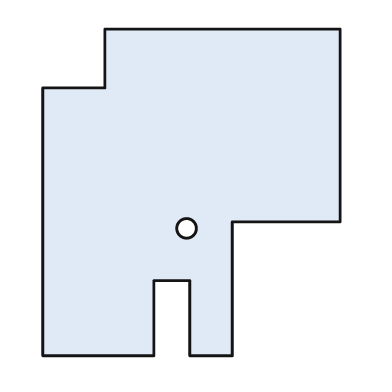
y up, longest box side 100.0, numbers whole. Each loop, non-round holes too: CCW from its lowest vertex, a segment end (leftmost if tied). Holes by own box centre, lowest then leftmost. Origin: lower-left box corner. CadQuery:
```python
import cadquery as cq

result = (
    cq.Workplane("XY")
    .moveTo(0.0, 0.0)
    .lineTo(34.0, 0.0)
    .lineTo(34.0, 23.0)
    .lineTo(45.0, 23.0)
    .lineTo(45.0, 0.0)
    .lineTo(58.0, 0.0)
    .lineTo(58.0, 41.0)
    .lineTo(91.0, 41.0)
    .lineTo(91.0, 100.0)
    .lineTo(19.0, 100.0)
    .lineTo(19.0, 82.0)
    .lineTo(0.0, 82.0)
    .close()
    .moveTo(44.0, 39.0)
    .circle(3.0)
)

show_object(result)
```